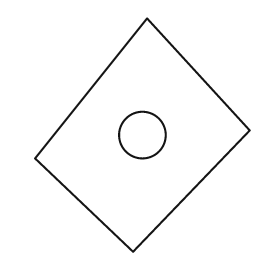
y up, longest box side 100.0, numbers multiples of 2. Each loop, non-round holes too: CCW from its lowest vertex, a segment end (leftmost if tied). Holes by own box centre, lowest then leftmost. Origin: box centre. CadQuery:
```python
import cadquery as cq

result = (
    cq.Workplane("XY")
    .moveTo(-4.0, -50.0)
    .lineTo(46.0, 2.0)
    .lineTo(2.0, 50.0)
    .lineTo(-46.0, -10.0)
    .close()
    .moveTo(0.0, 0.0)
    .circle(10.0)
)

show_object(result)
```